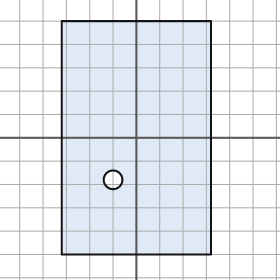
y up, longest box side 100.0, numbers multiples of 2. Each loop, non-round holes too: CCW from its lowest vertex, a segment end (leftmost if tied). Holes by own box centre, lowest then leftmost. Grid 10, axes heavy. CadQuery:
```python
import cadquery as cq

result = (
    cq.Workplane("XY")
    .moveTo(-32.0, -50.0)
    .lineTo(32.0, -50.0)
    .lineTo(32.0, 50.0)
    .lineTo(-32.0, 50.0)
    .close()
    .moveTo(-10.0, -18.0)
    .circle(4.0)
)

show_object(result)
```